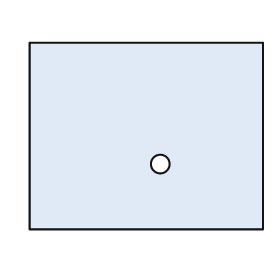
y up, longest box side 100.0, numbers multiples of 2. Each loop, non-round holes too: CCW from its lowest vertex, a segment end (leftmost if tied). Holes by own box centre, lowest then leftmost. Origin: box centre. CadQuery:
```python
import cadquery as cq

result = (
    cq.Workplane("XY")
    .moveTo(-50.0, -40.0)
    .lineTo(50.0, -40.0)
    .lineTo(50.0, 40.0)
    .lineTo(-50.0, 40.0)
    .close()
    .moveTo(6.0, -12.0)
    .circle(4.0)
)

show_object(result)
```